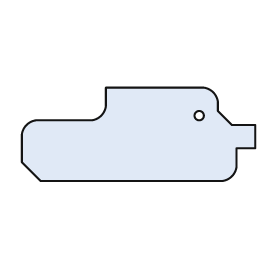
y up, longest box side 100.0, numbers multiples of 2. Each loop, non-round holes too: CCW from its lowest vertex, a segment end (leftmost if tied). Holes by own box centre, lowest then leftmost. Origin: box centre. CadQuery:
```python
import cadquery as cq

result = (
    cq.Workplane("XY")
    .moveTo(-42.0, -20.0)
    .lineTo(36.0, -20.0)
    .threePointArc((40.0, -18.0), (42.0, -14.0))
    .lineTo(42.0, -6.0)
    .lineTo(50.0, -6.0)
    .lineTo(50.0, 4.0)
    .lineTo(40.0, 4.0)
    .lineTo(34.0, 10.0)
    .lineTo(34.0, 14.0)
    .threePointArc((32.0, 18.0), (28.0, 20.0))
    .lineTo(-14.0, 20.0)
    .lineTo(-14.0, 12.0)
    .threePointArc((-16.0, 8.0), (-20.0, 6.0))
    .lineTo(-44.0, 6.0)
    .threePointArc((-48.0, 4.0), (-50.0, 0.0))
    .lineTo(-50.0, -12.0)
    .close()
    .moveTo(26.0, 8.0)
    .circle(2.0)
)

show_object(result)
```